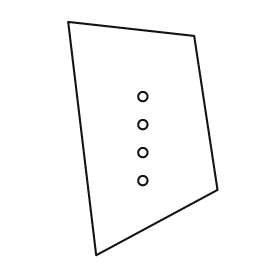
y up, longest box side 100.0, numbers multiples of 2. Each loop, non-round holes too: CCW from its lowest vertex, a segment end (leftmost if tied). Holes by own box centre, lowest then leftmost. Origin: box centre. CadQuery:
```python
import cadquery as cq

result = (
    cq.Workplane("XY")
    .moveTo(-20.0, -50.0)
    .lineTo(32.0, -22.0)
    .lineTo(22.0, 44.0)
    .lineTo(-32.0, 50.0)
    .close()
    .moveTo(0.0, -18.0)
    .circle(2.0)
    .moveTo(0.0, -6.0)
    .circle(2.0)
    .moveTo(0.0, 6.0)
    .circle(2.0)
    .moveTo(0.0, 18.0)
    .circle(2.0)
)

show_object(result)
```